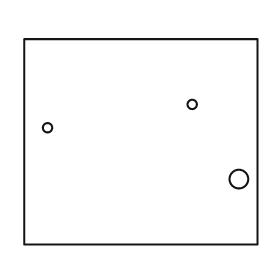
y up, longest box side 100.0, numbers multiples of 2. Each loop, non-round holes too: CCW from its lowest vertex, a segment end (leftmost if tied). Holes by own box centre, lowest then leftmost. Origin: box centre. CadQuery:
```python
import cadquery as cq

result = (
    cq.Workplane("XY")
    .moveTo(-50.0, -44.0)
    .lineTo(50.0, -44.0)
    .lineTo(50.0, 44.0)
    .lineTo(-50.0, 44.0)
    .close()
    .moveTo(42.0, -16.0)
    .circle(4.0)
    .moveTo(-40.0, 6.0)
    .circle(2.0)
    .moveTo(22.0, 16.0)
    .circle(2.0)
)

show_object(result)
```